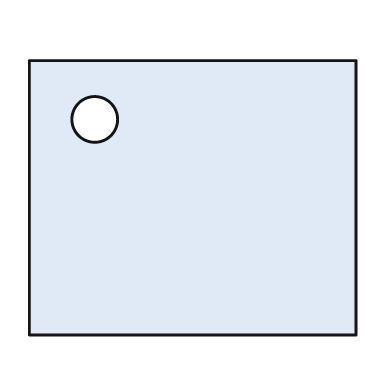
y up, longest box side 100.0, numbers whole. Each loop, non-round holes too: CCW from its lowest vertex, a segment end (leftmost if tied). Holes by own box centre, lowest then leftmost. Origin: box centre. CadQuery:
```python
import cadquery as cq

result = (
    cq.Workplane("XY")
    .moveTo(-50.0, -42.0)
    .lineTo(50.0, -42.0)
    .lineTo(50.0, 42.0)
    .lineTo(-50.0, 42.0)
    .close()
    .moveTo(-30.0, 24.0)
    .circle(7.0)
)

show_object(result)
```